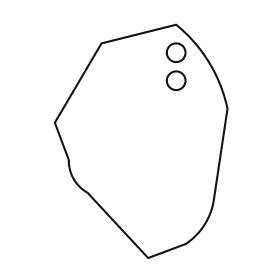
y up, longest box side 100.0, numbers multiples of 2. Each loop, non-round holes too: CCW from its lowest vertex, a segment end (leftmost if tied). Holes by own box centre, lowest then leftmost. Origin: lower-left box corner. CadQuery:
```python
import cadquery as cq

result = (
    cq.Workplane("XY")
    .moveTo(40.0, 0.0)
    .lineTo(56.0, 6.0)
    .threePointArc((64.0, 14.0), (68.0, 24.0))
    .lineTo(74.0, 64.0)
    .threePointArc((66.0, 84.0), (52.0, 100.0))
    .lineTo(20.0, 92.0)
    .lineTo(0.0, 58.0)
    .lineTo(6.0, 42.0)
    .threePointArc((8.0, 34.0), (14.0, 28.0))
    .close()
    .moveTo(52.0, 76.0)
    .circle(4.0)
    .moveTo(52.0, 88.0)
    .circle(4.0)
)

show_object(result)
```